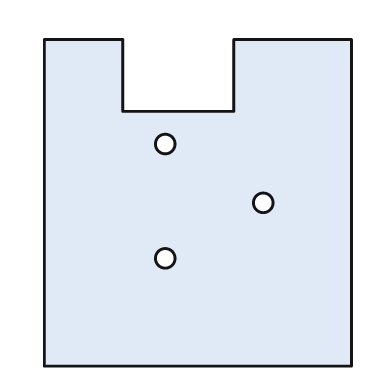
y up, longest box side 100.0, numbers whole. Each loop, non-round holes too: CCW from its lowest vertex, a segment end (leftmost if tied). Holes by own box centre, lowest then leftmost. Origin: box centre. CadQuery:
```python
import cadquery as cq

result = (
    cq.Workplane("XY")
    .moveTo(-47.0, -50.0)
    .lineTo(47.0, -50.0)
    .lineTo(47.0, 50.0)
    .lineTo(11.0, 50.0)
    .lineTo(11.0, 28.0)
    .lineTo(-23.0, 28.0)
    .lineTo(-23.0, 50.0)
    .lineTo(-47.0, 50.0)
    .close()
    .moveTo(-10.0, -17.0)
    .circle(3.0)
    .moveTo(20.0, 0.0)
    .circle(3.0)
    .moveTo(-10.0, 18.0)
    .circle(3.0)
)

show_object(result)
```